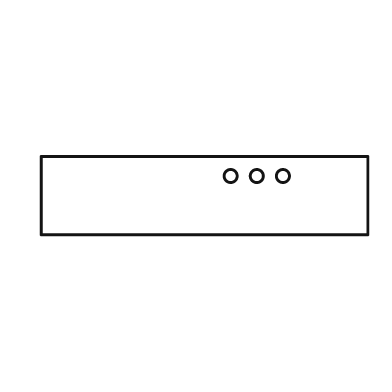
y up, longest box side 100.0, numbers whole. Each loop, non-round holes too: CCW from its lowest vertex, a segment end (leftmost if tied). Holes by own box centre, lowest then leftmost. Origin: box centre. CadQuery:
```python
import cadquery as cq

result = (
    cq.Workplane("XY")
    .moveTo(-50.0, -12.0)
    .lineTo(50.0, -12.0)
    .lineTo(50.0, 12.0)
    .lineTo(-50.0, 12.0)
    .close()
    .moveTo(8.0, 6.0)
    .circle(2.0)
    .moveTo(16.0, 6.0)
    .circle(2.0)
    .moveTo(24.0, 6.0)
    .circle(2.0)
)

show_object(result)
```